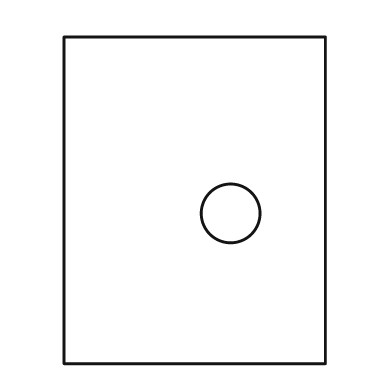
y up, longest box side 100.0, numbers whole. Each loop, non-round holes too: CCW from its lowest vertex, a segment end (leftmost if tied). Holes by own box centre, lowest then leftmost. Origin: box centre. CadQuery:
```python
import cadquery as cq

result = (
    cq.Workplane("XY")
    .moveTo(-40.0, -50.0)
    .lineTo(40.0, -50.0)
    .lineTo(40.0, 50.0)
    .lineTo(-40.0, 50.0)
    .close()
    .moveTo(11.0, -4.0)
    .circle(9.0)
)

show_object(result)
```